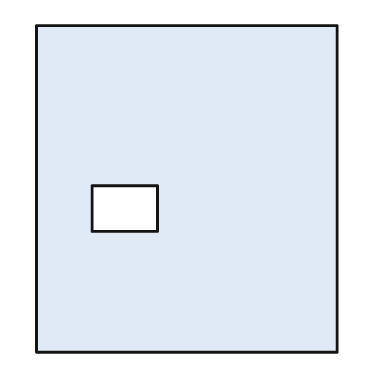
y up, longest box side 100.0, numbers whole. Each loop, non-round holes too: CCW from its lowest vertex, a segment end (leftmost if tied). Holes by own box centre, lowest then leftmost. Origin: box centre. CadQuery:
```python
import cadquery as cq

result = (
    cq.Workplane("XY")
    .moveTo(-46.0, -50.0)
    .lineTo(46.0, -50.0)
    .lineTo(46.0, 50.0)
    .lineTo(-46.0, 50.0)
    .close()
    .moveTo(-29.0, -13.0)
    .lineTo(-9.0, -13.0)
    .lineTo(-9.0, 1.0)
    .lineTo(-29.0, 1.0)
    .close()
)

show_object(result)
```